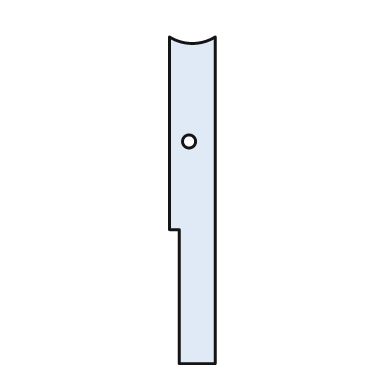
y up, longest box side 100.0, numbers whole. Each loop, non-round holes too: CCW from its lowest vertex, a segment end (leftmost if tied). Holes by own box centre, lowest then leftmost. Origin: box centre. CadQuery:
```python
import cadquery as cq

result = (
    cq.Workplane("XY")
    .moveTo(-4.0, -50.0)
    .lineTo(7.0, -50.0)
    .lineTo(7.0, 50.0)
    .threePointArc((0.0, 48.0), (-7.0, 50.0))
    .lineTo(-7.0, -9.0)
    .lineTo(-4.0, -9.0)
    .close()
    .moveTo(-1.0, 18.0)
    .circle(2.0)
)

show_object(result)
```